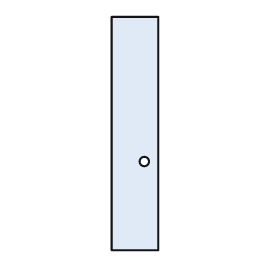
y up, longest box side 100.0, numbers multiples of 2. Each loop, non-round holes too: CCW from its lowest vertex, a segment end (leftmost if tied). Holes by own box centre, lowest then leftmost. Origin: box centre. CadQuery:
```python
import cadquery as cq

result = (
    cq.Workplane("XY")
    .moveTo(-10.0, -50.0)
    .lineTo(10.0, -50.0)
    .lineTo(10.0, 50.0)
    .lineTo(-10.0, 50.0)
    .close()
    .moveTo(4.0, -12.0)
    .circle(2.0)
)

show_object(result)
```